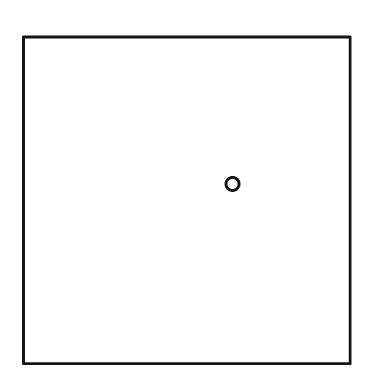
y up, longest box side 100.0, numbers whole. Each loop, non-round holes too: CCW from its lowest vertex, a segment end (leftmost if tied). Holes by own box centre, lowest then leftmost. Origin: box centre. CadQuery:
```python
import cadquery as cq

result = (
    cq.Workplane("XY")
    .moveTo(-50.0, -50.0)
    .lineTo(50.0, -50.0)
    .lineTo(50.0, 50.0)
    .lineTo(-50.0, 50.0)
    .close()
    .moveTo(14.0, 5.0)
    .circle(2.0)
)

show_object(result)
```